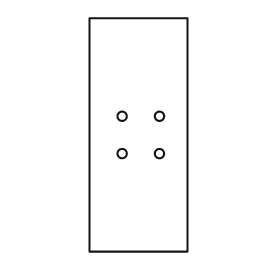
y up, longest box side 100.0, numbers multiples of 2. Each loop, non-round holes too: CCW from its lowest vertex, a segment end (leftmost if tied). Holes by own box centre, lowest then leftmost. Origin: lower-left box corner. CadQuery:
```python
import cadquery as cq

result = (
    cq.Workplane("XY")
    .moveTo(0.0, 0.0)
    .lineTo(42.0, 0.0)
    .lineTo(42.0, 100.0)
    .lineTo(0.0, 100.0)
    .close()
    .moveTo(14.0, 42.0)
    .circle(2.0)
    .moveTo(30.0, 42.0)
    .circle(2.0)
    .moveTo(14.0, 58.0)
    .circle(2.0)
    .moveTo(30.0, 58.0)
    .circle(2.0)
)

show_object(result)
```